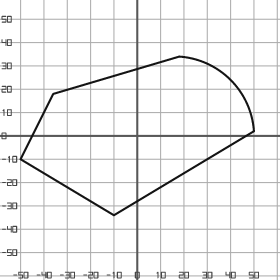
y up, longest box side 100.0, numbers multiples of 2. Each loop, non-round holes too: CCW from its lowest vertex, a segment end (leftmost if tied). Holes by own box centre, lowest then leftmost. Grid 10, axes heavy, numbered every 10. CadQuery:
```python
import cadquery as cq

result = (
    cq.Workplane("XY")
    .moveTo(-10.0, -34.0)
    .lineTo(50.0, 2.0)
    .threePointArc((40.0, 24.0), (18.0, 34.0))
    .lineTo(-36.0, 18.0)
    .lineTo(-50.0, -10.0)
    .close()
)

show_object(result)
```